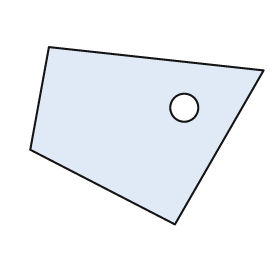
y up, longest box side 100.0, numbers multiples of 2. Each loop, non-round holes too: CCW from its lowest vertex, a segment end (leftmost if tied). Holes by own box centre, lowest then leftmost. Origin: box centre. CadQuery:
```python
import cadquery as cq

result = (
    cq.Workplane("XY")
    .moveTo(12.0, -38.0)
    .lineTo(50.0, 28.0)
    .lineTo(-42.0, 38.0)
    .lineTo(-50.0, -6.0)
    .close()
    .moveTo(16.0, 12.0)
    .circle(6.0)
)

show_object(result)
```